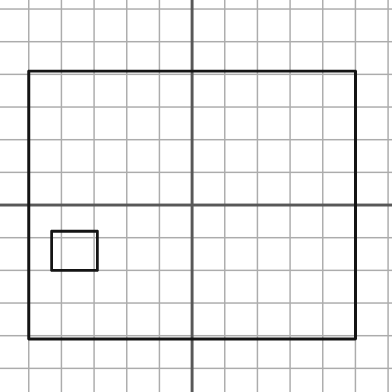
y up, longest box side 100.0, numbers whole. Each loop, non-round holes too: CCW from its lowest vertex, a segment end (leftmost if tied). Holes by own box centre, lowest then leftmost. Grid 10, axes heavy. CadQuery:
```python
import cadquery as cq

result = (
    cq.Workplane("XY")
    .moveTo(-50.0, -41.0)
    .lineTo(50.0, -41.0)
    .lineTo(50.0, 41.0)
    .lineTo(-50.0, 41.0)
    .close()
    .moveTo(-43.0, -20.0)
    .lineTo(-29.0, -20.0)
    .lineTo(-29.0, -8.0)
    .lineTo(-43.0, -8.0)
    .close()
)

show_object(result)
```